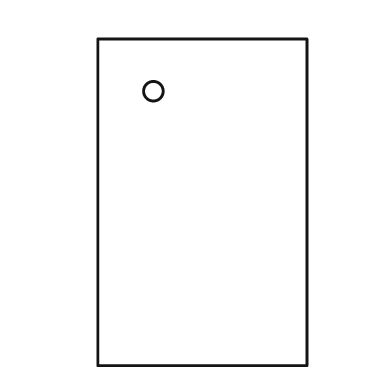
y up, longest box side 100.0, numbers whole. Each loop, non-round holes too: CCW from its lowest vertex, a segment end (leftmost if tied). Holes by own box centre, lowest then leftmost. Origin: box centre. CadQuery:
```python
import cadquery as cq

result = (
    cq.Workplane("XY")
    .moveTo(-32.0, -50.0)
    .lineTo(32.0, -50.0)
    .lineTo(32.0, 50.0)
    .lineTo(-32.0, 50.0)
    .close()
    .moveTo(-15.0, 34.0)
    .circle(3.0)
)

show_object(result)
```